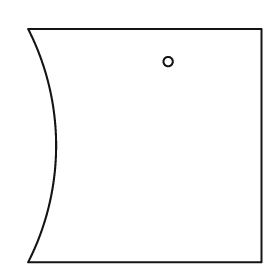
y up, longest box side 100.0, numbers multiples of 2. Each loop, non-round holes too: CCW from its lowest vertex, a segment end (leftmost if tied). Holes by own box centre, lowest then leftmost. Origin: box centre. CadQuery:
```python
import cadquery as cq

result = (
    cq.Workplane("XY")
    .moveTo(-50.0, -50.0)
    .lineTo(50.0, -50.0)
    .lineTo(50.0, 50.0)
    .lineTo(-50.0, 50.0)
    .threePointArc((-38.0, 0.0), (-50.0, -50.0))
    .close()
    .moveTo(10.0, 36.0)
    .circle(2.0)
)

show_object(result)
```